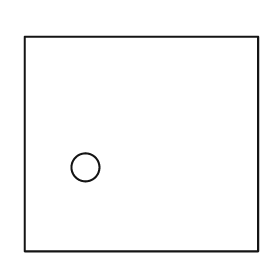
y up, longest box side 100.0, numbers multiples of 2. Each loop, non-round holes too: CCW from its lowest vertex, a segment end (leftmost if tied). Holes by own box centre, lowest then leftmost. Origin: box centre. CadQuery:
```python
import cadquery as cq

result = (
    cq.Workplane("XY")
    .moveTo(-50.0, -46.0)
    .lineTo(50.0, -46.0)
    .lineTo(50.0, 46.0)
    .lineTo(-50.0, 46.0)
    .close()
    .moveTo(-24.0, -10.0)
    .circle(6.0)
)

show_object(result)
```